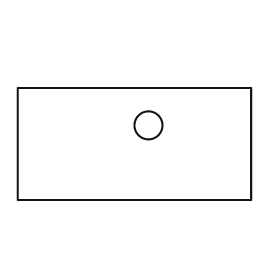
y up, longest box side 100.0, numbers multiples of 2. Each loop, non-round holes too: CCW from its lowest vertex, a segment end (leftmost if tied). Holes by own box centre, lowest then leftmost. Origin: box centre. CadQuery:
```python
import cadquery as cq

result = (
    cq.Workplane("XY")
    .moveTo(-50.0, -24.0)
    .lineTo(50.0, -24.0)
    .lineTo(50.0, 24.0)
    .lineTo(-50.0, 24.0)
    .close()
    .moveTo(6.0, 8.0)
    .circle(6.0)
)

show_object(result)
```